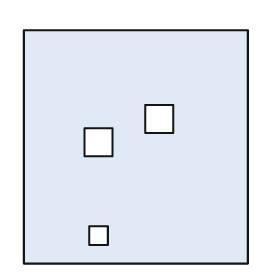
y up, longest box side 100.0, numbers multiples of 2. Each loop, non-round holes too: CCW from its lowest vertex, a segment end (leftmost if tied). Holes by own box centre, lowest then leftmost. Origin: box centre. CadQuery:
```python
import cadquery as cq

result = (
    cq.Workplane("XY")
    .moveTo(-48.0, -50.0)
    .lineTo(48.0, -50.0)
    .lineTo(48.0, 50.0)
    .lineTo(-48.0, 50.0)
    .close()
    .moveTo(-20.0, -42.0)
    .lineTo(-12.0, -42.0)
    .lineTo(-12.0, -34.0)
    .lineTo(-20.0, -34.0)
    .close()
    .moveTo(-22.0, -4.0)
    .lineTo(-10.0, -4.0)
    .lineTo(-10.0, 8.0)
    .lineTo(-22.0, 8.0)
    .close()
    .moveTo(4.0, 6.0)
    .lineTo(16.0, 6.0)
    .lineTo(16.0, 18.0)
    .lineTo(4.0, 18.0)
    .close()
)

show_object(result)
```